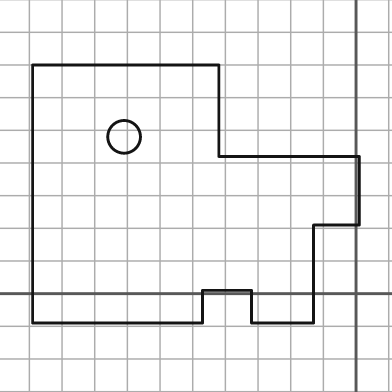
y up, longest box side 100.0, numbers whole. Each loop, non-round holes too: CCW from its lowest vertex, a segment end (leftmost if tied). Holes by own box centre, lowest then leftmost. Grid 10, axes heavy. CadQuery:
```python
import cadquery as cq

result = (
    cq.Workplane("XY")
    .moveTo(-99.0, -9.0)
    .lineTo(-47.0, -9.0)
    .lineTo(-47.0, 1.0)
    .lineTo(-32.0, 1.0)
    .lineTo(-32.0, -9.0)
    .lineTo(-13.0, -9.0)
    .lineTo(-13.0, 21.0)
    .lineTo(1.0, 21.0)
    .lineTo(1.0, 42.0)
    .lineTo(-42.0, 42.0)
    .lineTo(-42.0, 70.0)
    .lineTo(-99.0, 70.0)
    .close()
    .moveTo(-71.0, 48.0)
    .circle(5.0)
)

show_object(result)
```